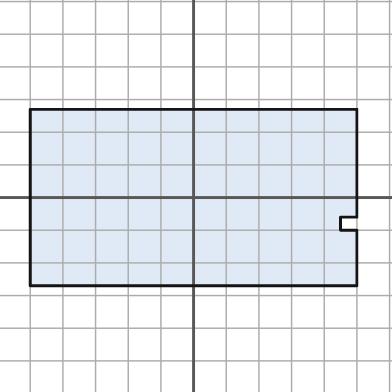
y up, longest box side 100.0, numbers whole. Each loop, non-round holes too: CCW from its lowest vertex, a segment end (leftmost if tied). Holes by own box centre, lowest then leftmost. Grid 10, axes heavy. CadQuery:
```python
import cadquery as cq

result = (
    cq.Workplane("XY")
    .moveTo(-50.0, -27.0)
    .lineTo(50.0, -27.0)
    .lineTo(50.0, -10.0)
    .lineTo(45.0, -10.0)
    .lineTo(45.0, -6.0)
    .lineTo(50.0, -6.0)
    .lineTo(50.0, 27.0)
    .lineTo(-50.0, 27.0)
    .close()
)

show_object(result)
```